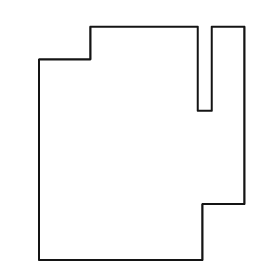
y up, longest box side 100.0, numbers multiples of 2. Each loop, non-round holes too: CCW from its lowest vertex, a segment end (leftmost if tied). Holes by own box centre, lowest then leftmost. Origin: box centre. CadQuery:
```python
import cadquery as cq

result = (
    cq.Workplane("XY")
    .moveTo(-44.0, -50.0)
    .lineTo(26.0, -50.0)
    .lineTo(26.0, -26.0)
    .lineTo(44.0, -26.0)
    .lineTo(44.0, 50.0)
    .lineTo(30.0, 50.0)
    .lineTo(30.0, 14.0)
    .lineTo(24.0, 14.0)
    .lineTo(24.0, 50.0)
    .lineTo(-22.0, 50.0)
    .lineTo(-22.0, 36.0)
    .lineTo(-44.0, 36.0)
    .close()
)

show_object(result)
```